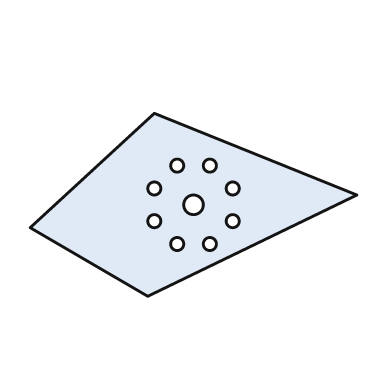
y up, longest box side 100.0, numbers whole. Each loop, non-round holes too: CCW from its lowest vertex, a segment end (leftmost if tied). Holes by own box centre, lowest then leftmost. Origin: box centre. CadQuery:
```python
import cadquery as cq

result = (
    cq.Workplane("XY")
    .moveTo(-14.0, -28.0)
    .lineTo(50.0, 3.0)
    .lineTo(-12.0, 28.0)
    .lineTo(-50.0, -7.0)
    .close()
    .moveTo(-5.0, -12.0)
    .circle(2.0)
    .moveTo(5.0, -12.0)
    .circle(2.0)
    .moveTo(-12.0, -5.0)
    .circle(2.0)
    .moveTo(12.0, -5.0)
    .circle(2.0)
    .moveTo(0.0, 0.0)
    .circle(3.0)
    .moveTo(-12.0, 5.0)
    .circle(2.0)
    .moveTo(12.0, 5.0)
    .circle(2.0)
    .moveTo(-5.0, 12.0)
    .circle(2.0)
    .moveTo(5.0, 12.0)
    .circle(2.0)
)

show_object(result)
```